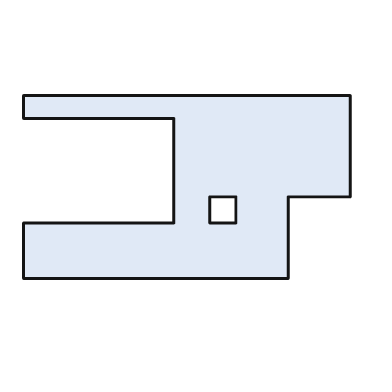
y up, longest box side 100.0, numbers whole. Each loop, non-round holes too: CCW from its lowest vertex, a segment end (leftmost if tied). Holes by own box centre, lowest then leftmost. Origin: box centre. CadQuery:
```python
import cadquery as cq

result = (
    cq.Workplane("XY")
    .moveTo(-50.0, -28.0)
    .lineTo(31.0, -28.0)
    .lineTo(31.0, -3.0)
    .lineTo(50.0, -3.0)
    .lineTo(50.0, 28.0)
    .lineTo(-50.0, 28.0)
    .lineTo(-50.0, 21.0)
    .lineTo(-4.0, 21.0)
    .lineTo(-4.0, -11.0)
    .lineTo(-50.0, -11.0)
    .close()
    .moveTo(7.0, -11.0)
    .lineTo(15.0, -11.0)
    .lineTo(15.0, -3.0)
    .lineTo(7.0, -3.0)
    .close()
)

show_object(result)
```